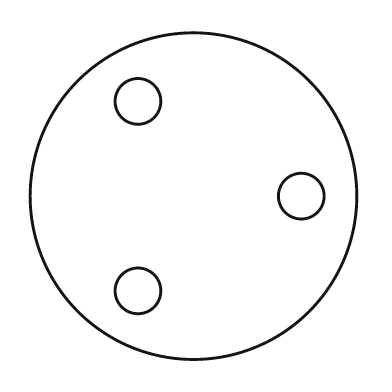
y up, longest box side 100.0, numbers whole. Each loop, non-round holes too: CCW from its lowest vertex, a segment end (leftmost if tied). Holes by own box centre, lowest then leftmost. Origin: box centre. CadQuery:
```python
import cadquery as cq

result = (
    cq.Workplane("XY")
    .moveTo(0.0, 0.0)
    .circle(50.0)
    .moveTo(-17.0, -29.0)
    .circle(7.0)
    .moveTo(33.0, 0.0)
    .circle(7.0)
    .moveTo(-17.0, 29.0)
    .circle(7.0)
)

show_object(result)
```